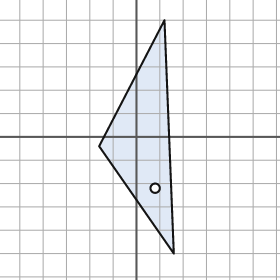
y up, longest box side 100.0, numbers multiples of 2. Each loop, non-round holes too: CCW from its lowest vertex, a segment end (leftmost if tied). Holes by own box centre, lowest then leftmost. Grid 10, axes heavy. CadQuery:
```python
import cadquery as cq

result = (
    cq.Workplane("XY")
    .moveTo(16.0, -50.0)
    .lineTo(12.0, 50.0)
    .lineTo(-16.0, -4.0)
    .close()
    .moveTo(8.0, -22.0)
    .circle(2.0)
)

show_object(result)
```